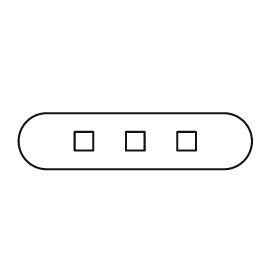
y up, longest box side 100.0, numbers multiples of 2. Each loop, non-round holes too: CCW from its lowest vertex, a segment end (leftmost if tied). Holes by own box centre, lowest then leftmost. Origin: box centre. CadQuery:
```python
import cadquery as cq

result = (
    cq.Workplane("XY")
    .moveTo(-38.0, -12.0)
    .lineTo(38.0, -12.0)
    .threePointArc((50.0, 0.0), (38.0, 12.0))
    .lineTo(-38.0, 12.0)
    .threePointArc((-50.0, 0.0), (-38.0, -12.0))
    .close()
    .moveTo(-26.0, -4.0)
    .lineTo(-18.0, -4.0)
    .lineTo(-18.0, 4.0)
    .lineTo(-26.0, 4.0)
    .close()
    .moveTo(-4.0, -4.0)
    .lineTo(4.0, -4.0)
    .lineTo(4.0, 4.0)
    .lineTo(-4.0, 4.0)
    .close()
    .moveTo(18.0, -4.0)
    .lineTo(26.0, -4.0)
    .lineTo(26.0, 4.0)
    .lineTo(18.0, 4.0)
    .close()
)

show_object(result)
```